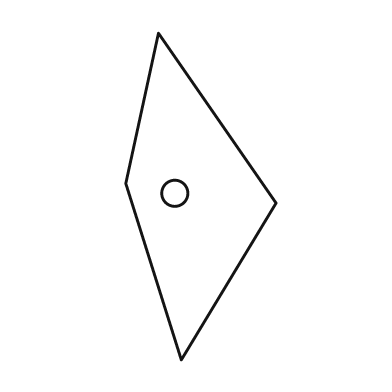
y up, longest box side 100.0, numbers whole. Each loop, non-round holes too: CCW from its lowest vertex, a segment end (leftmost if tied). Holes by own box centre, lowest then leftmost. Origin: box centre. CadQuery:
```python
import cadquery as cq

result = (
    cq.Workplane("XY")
    .moveTo(-6.0, -50.0)
    .lineTo(23.0, -2.0)
    .lineTo(-13.0, 50.0)
    .lineTo(-23.0, 4.0)
    .close()
    .moveTo(-8.0, 1.0)
    .circle(4.0)
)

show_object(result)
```